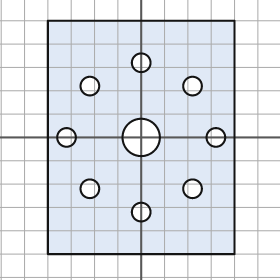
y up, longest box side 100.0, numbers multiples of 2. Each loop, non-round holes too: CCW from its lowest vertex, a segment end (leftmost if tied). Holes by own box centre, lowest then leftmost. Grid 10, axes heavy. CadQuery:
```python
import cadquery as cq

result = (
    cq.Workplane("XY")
    .moveTo(-40.0, -50.0)
    .lineTo(40.0, -50.0)
    .lineTo(40.0, 50.0)
    .lineTo(-40.0, 50.0)
    .close()
    .moveTo(0.0, -32.0)
    .circle(4.0)
    .moveTo(-22.0, -22.0)
    .circle(4.0)
    .moveTo(22.0, -22.0)
    .circle(4.0)
    .moveTo(-32.0, 0.0)
    .circle(4.0)
    .moveTo(0.0, 0.0)
    .circle(8.0)
    .moveTo(32.0, 0.0)
    .circle(4.0)
    .moveTo(-22.0, 22.0)
    .circle(4.0)
    .moveTo(22.0, 22.0)
    .circle(4.0)
    .moveTo(0.0, 32.0)
    .circle(4.0)
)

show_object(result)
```